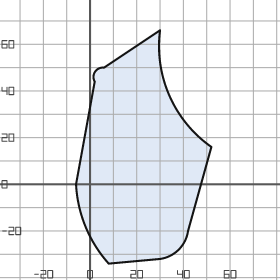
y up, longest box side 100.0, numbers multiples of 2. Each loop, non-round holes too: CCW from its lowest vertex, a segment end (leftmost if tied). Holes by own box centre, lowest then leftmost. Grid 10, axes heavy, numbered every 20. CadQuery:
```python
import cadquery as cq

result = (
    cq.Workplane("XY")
    .moveTo(8.0, -34.0)
    .lineTo(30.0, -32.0)
    .threePointArc((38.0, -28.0), (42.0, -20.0))
    .lineTo(52.0, 16.0)
    .threePointArc((34.0, 38.0), (30.0, 66.0))
    .lineTo(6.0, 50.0)
    .threePointArc((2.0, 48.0), (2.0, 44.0))
    .lineTo(-6.0, 0.0)
    .threePointArc((-2.0, -18.0), (8.0, -34.0))
    .close()
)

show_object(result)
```